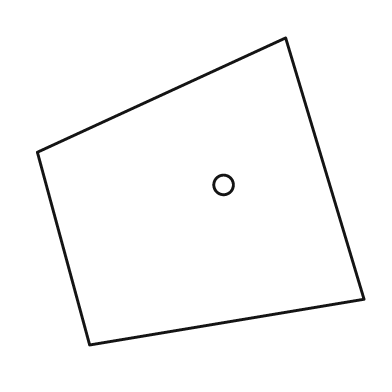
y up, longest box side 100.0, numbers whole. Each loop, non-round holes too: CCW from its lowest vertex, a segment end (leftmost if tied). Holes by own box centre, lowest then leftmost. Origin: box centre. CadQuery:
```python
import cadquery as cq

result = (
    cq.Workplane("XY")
    .moveTo(-34.0, -47.0)
    .lineTo(50.0, -33.0)
    .lineTo(26.0, 47.0)
    .lineTo(-50.0, 12.0)
    .close()
    .moveTo(7.0, 2.0)
    .circle(3.0)
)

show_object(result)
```